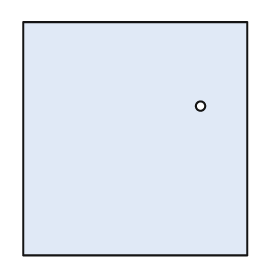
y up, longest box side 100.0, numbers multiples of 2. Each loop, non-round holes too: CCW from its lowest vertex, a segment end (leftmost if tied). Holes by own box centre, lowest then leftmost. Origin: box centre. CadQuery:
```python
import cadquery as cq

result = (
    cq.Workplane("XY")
    .moveTo(-48.0, -50.0)
    .lineTo(48.0, -50.0)
    .lineTo(48.0, 50.0)
    .lineTo(-48.0, 50.0)
    .close()
    .moveTo(28.0, 14.0)
    .circle(2.0)
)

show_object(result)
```